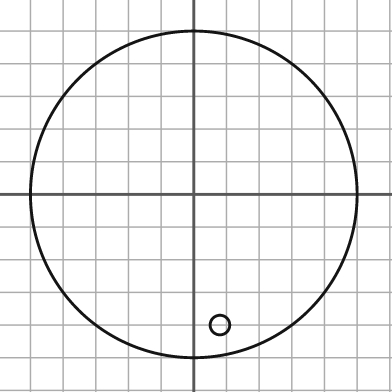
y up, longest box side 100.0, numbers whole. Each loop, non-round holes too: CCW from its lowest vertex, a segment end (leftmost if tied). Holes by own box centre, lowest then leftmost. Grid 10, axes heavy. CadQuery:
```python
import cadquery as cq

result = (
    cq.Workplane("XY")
    .moveTo(0.0, 0.0)
    .circle(50.0)
    .moveTo(8.0, -40.0)
    .circle(3.0)
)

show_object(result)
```